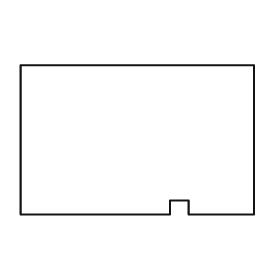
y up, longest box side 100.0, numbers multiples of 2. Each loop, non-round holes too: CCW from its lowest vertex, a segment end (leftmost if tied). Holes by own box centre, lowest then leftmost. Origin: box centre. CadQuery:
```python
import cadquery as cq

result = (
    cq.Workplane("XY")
    .moveTo(-50.0, -32.0)
    .lineTo(14.0, -32.0)
    .lineTo(14.0, -26.0)
    .lineTo(22.0, -26.0)
    .lineTo(22.0, -32.0)
    .lineTo(50.0, -32.0)
    .lineTo(50.0, 32.0)
    .lineTo(-50.0, 32.0)
    .close()
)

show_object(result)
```